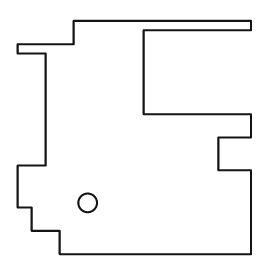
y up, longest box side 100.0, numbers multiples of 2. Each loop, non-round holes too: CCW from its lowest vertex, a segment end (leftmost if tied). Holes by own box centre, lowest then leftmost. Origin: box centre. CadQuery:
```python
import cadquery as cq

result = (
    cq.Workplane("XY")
    .moveTo(-32.0, -50.0)
    .lineTo(50.0, -50.0)
    .lineTo(50.0, -14.0)
    .lineTo(36.0, -14.0)
    .lineTo(36.0, 0.0)
    .lineTo(50.0, 0.0)
    .lineTo(50.0, 10.0)
    .lineTo(4.0, 10.0)
    .lineTo(4.0, 46.0)
    .lineTo(50.0, 46.0)
    .lineTo(50.0, 50.0)
    .lineTo(-26.0, 50.0)
    .lineTo(-26.0, 40.0)
    .lineTo(-50.0, 40.0)
    .lineTo(-50.0, 36.0)
    .lineTo(-38.0, 36.0)
    .lineTo(-38.0, -12.0)
    .lineTo(-50.0, -12.0)
    .lineTo(-50.0, -30.0)
    .lineTo(-44.0, -30.0)
    .lineTo(-44.0, -40.0)
    .lineTo(-32.0, -40.0)
    .close()
    .moveTo(-20.0, -28.0)
    .circle(4.0)
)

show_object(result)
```